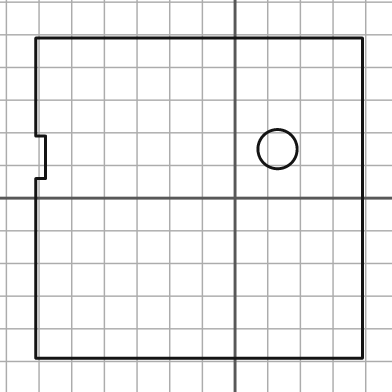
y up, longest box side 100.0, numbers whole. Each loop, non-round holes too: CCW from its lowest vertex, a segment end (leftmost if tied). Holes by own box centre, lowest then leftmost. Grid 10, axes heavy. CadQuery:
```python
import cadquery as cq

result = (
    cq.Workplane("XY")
    .moveTo(-61.0, -49.0)
    .lineTo(39.0, -49.0)
    .lineTo(39.0, 49.0)
    .lineTo(-61.0, 49.0)
    .lineTo(-61.0, 19.0)
    .lineTo(-58.0, 19.0)
    .lineTo(-58.0, 6.0)
    .lineTo(-61.0, 6.0)
    .close()
    .moveTo(13.0, 15.0)
    .circle(6.0)
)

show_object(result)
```